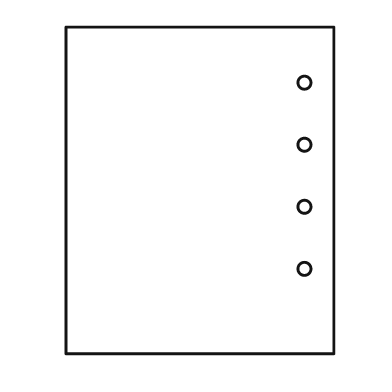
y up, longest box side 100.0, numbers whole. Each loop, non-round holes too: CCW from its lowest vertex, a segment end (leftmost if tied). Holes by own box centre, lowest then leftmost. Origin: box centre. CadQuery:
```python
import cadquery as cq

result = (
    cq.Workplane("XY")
    .moveTo(-41.0, -50.0)
    .lineTo(41.0, -50.0)
    .lineTo(41.0, 50.0)
    .lineTo(-41.0, 50.0)
    .close()
    .moveTo(32.0, -24.0)
    .circle(2.0)
    .moveTo(32.0, -5.0)
    .circle(2.0)
    .moveTo(32.0, 14.0)
    .circle(2.0)
    .moveTo(32.0, 33.0)
    .circle(2.0)
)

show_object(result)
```